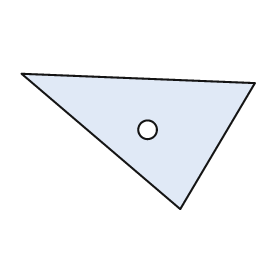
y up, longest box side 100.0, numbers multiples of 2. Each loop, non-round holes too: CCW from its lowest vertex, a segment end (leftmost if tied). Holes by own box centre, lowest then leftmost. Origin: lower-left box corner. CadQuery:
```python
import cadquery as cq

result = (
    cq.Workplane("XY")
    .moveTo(68.0, 0.0)
    .lineTo(100.0, 54.0)
    .lineTo(0.0, 58.0)
    .close()
    .moveTo(54.0, 34.0)
    .circle(4.0)
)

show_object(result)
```